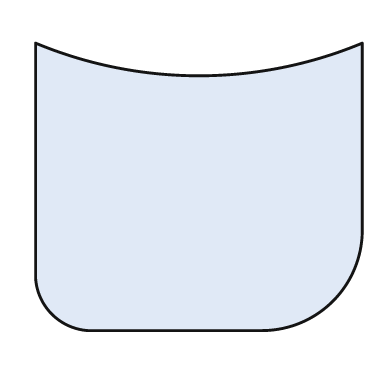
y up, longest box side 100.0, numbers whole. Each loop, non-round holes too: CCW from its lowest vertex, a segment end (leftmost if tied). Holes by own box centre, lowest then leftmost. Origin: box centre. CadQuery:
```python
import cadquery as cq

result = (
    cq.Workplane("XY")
    .moveTo(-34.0, -44.0)
    .lineTo(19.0, -44.0)
    .threePointArc((41.0, -35.0), (50.0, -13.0))
    .lineTo(50.0, 44.0)
    .threePointArc((0.0, 34.0), (-50.0, 44.0))
    .lineTo(-50.0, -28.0)
    .threePointArc((-45.0, -39.0), (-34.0, -44.0))
    .close()
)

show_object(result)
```